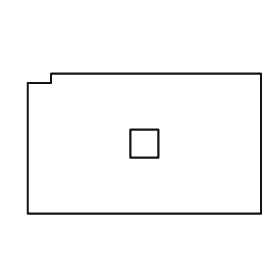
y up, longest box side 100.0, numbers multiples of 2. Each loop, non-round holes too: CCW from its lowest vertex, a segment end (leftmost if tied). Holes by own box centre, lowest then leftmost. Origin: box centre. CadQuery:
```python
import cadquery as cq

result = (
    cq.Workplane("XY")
    .moveTo(-50.0, -30.0)
    .lineTo(50.0, -30.0)
    .lineTo(50.0, 30.0)
    .lineTo(-40.0, 30.0)
    .lineTo(-40.0, 26.0)
    .lineTo(-50.0, 26.0)
    .close()
    .moveTo(-6.0, -6.0)
    .lineTo(6.0, -6.0)
    .lineTo(6.0, 6.0)
    .lineTo(-6.0, 6.0)
    .close()
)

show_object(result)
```